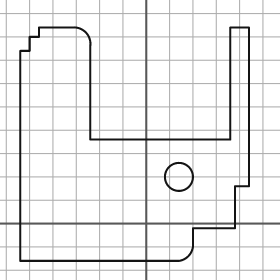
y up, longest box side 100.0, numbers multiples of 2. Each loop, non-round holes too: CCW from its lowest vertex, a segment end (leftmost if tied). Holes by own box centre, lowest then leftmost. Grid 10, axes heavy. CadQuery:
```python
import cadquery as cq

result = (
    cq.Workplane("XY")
    .moveTo(-54.0, -16.0)
    .lineTo(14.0, -16.0)
    .threePointArc((18.0, -14.0), (20.0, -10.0))
    .lineTo(20.0, -2.0)
    .lineTo(38.0, -2.0)
    .lineTo(38.0, 16.0)
    .lineTo(44.0, 16.0)
    .lineTo(44.0, 84.0)
    .lineTo(36.0, 84.0)
    .lineTo(36.0, 36.0)
    .lineTo(-24.0, 36.0)
    .lineTo(-24.0, 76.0)
    .threePointArc((-26.0, 82.0), (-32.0, 84.0))
    .lineTo(-46.0, 84.0)
    .lineTo(-46.0, 80.0)
    .lineTo(-50.0, 80.0)
    .lineTo(-50.0, 74.0)
    .lineTo(-54.0, 74.0)
    .close()
    .moveTo(14.0, 20.0)
    .circle(6.0)
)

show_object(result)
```